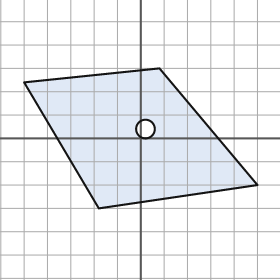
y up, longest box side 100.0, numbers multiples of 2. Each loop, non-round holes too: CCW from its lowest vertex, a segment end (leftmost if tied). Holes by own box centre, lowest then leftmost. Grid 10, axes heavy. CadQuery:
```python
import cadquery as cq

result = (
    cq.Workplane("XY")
    .moveTo(-18.0, -30.0)
    .lineTo(50.0, -20.0)
    .lineTo(8.0, 30.0)
    .lineTo(-50.0, 24.0)
    .close()
    .moveTo(2.0, 4.0)
    .circle(4.0)
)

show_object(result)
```